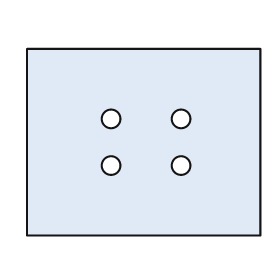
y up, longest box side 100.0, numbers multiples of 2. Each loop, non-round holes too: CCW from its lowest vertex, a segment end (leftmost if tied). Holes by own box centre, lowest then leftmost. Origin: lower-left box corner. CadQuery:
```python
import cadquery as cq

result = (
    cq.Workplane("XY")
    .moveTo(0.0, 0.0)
    .lineTo(100.0, 0.0)
    .lineTo(100.0, 80.0)
    .lineTo(0.0, 80.0)
    .close()
    .moveTo(36.0, 30.0)
    .circle(4.0)
    .moveTo(66.0, 30.0)
    .circle(4.0)
    .moveTo(36.0, 50.0)
    .circle(4.0)
    .moveTo(66.0, 50.0)
    .circle(4.0)
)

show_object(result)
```